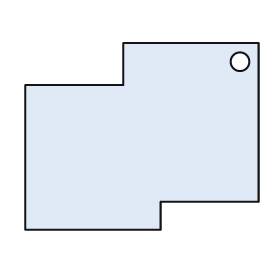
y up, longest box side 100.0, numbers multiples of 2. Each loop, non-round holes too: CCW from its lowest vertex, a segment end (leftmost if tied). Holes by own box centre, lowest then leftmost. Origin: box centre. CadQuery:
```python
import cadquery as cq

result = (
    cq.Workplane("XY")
    .moveTo(-50.0, -40.0)
    .lineTo(8.0, -40.0)
    .lineTo(8.0, -28.0)
    .lineTo(50.0, -28.0)
    .lineTo(50.0, 40.0)
    .lineTo(-8.0, 40.0)
    .lineTo(-8.0, 22.0)
    .lineTo(-50.0, 22.0)
    .close()
    .moveTo(42.0, 32.0)
    .circle(4.0)
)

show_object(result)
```